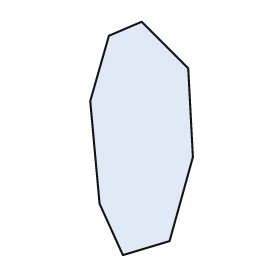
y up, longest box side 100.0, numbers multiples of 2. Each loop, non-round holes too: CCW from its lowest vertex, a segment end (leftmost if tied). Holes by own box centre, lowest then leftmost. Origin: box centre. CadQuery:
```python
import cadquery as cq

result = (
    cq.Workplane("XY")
    .moveTo(-8.0, -50.0)
    .lineTo(12.0, -44.0)
    .lineTo(22.0, -8.0)
    .lineTo(20.0, 30.0)
    .lineTo(0.0, 50.0)
    .lineTo(-14.0, 44.0)
    .lineTo(-22.0, 16.0)
    .lineTo(-18.0, -28.0)
    .close()
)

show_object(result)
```